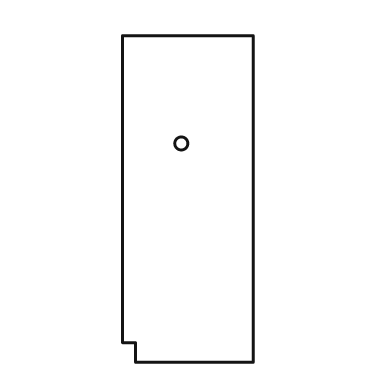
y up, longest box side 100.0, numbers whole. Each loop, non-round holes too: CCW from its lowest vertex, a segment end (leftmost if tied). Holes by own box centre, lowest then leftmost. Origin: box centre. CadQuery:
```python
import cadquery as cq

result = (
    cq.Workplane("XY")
    .moveTo(-16.0, -50.0)
    .lineTo(20.0, -50.0)
    .lineTo(20.0, 50.0)
    .lineTo(-20.0, 50.0)
    .lineTo(-20.0, -44.0)
    .lineTo(-16.0, -44.0)
    .close()
    .moveTo(-2.0, 17.0)
    .circle(2.0)
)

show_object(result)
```